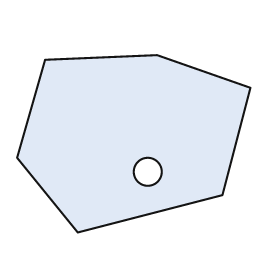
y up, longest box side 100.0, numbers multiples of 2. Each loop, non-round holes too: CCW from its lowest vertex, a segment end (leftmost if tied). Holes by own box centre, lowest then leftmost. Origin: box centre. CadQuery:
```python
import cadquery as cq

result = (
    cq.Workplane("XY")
    .moveTo(-24.0, -38.0)
    .lineTo(38.0, -22.0)
    .lineTo(50.0, 24.0)
    .lineTo(10.0, 38.0)
    .lineTo(-38.0, 36.0)
    .lineTo(-50.0, -6.0)
    .close()
    .moveTo(6.0, -12.0)
    .circle(6.0)
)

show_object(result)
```